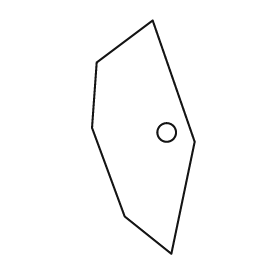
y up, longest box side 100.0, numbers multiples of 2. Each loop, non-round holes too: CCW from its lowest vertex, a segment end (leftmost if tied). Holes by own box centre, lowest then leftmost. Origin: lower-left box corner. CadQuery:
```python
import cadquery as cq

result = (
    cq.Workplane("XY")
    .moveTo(34.0, 0.0)
    .lineTo(44.0, 48.0)
    .lineTo(26.0, 100.0)
    .lineTo(2.0, 82.0)
    .lineTo(0.0, 54.0)
    .lineTo(14.0, 16.0)
    .close()
    .moveTo(32.0, 52.0)
    .circle(4.0)
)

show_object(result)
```